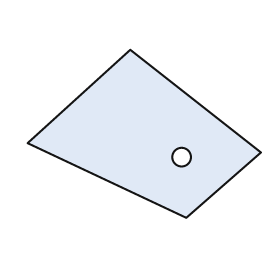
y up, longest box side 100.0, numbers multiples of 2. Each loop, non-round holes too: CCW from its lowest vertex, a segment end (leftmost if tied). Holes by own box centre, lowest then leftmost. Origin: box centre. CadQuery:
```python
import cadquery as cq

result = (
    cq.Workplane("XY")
    .moveTo(18.0, -36.0)
    .lineTo(50.0, -8.0)
    .lineTo(-6.0, 36.0)
    .lineTo(-50.0, -4.0)
    .close()
    .moveTo(16.0, -10.0)
    .circle(4.0)
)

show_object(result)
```